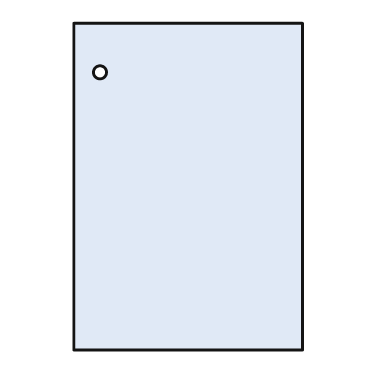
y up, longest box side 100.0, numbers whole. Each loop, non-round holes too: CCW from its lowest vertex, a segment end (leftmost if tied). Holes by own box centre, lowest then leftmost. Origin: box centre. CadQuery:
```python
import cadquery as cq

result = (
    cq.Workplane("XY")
    .moveTo(-35.0, -50.0)
    .lineTo(35.0, -50.0)
    .lineTo(35.0, 50.0)
    .lineTo(-35.0, 50.0)
    .close()
    .moveTo(-27.0, 35.0)
    .circle(2.0)
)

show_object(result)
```